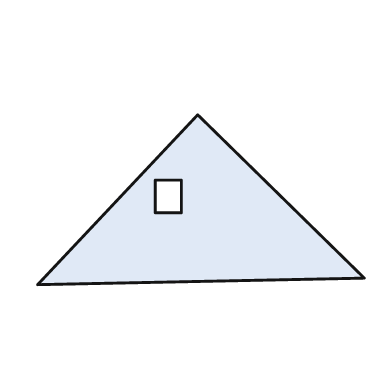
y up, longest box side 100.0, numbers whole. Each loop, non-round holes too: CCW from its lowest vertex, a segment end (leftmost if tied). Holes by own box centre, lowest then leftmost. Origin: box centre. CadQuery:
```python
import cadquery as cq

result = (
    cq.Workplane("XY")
    .moveTo(-50.0, -26.0)
    .lineTo(50.0, -24.0)
    .lineTo(-1.0, 26.0)
    .close()
    .moveTo(-14.0, -4.0)
    .lineTo(-6.0, -4.0)
    .lineTo(-6.0, 6.0)
    .lineTo(-14.0, 6.0)
    .close()
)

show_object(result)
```